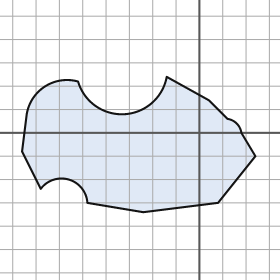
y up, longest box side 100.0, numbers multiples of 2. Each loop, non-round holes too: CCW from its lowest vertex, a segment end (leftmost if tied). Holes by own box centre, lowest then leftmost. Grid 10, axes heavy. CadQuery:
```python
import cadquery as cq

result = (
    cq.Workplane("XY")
    .moveTo(-24.0, -34.0)
    .lineTo(8.0, -30.0)
    .lineTo(24.0, -10.0)
    .lineTo(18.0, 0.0)
    .threePointArc((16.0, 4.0), (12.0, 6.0))
    .lineTo(4.0, 14.0)
    .lineTo(-14.0, 24.0)
    .threePointArc((-32.0, 8.0), (-52.0, 22.0))
    .threePointArc((-66.0, 20.0), (-74.0, 8.0))
    .lineTo(-76.0, -8.0)
    .lineTo(-68.0, -24.0)
    .threePointArc((-56.0, -20.0), (-48.0, -30.0))
    .close()
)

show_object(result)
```